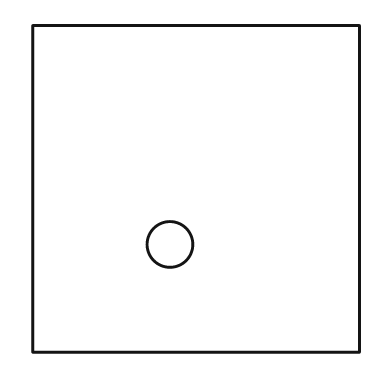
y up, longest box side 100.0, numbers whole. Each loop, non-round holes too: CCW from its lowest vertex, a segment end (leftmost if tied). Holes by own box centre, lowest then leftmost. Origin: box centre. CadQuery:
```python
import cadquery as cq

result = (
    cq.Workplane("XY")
    .moveTo(-50.0, -50.0)
    .lineTo(50.0, -50.0)
    .lineTo(50.0, 50.0)
    .lineTo(-50.0, 50.0)
    .close()
    .moveTo(-8.0, -17.0)
    .circle(7.0)
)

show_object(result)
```